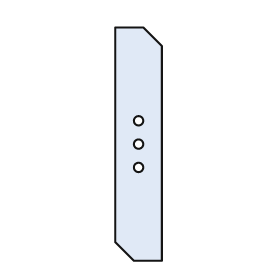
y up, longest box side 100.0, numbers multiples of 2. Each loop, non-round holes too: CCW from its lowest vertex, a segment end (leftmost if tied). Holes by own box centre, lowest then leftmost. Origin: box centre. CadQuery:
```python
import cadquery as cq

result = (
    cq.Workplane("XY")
    .moveTo(-2.0, -50.0)
    .lineTo(10.0, -50.0)
    .lineTo(10.0, 42.0)
    .lineTo(2.0, 50.0)
    .lineTo(-10.0, 50.0)
    .lineTo(-10.0, -42.0)
    .close()
    .moveTo(0.0, -10.0)
    .circle(2.0)
    .moveTo(0.0, 0.0)
    .circle(2.0)
    .moveTo(0.0, 10.0)
    .circle(2.0)
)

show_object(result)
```